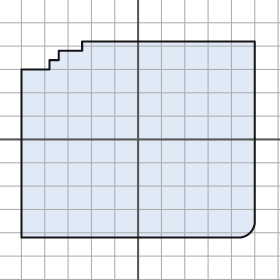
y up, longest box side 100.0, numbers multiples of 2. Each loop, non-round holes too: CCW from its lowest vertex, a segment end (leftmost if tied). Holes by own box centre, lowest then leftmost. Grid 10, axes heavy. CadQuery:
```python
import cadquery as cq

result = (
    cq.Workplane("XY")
    .moveTo(-50.0, -42.0)
    .lineTo(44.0, -42.0)
    .threePointArc((48.0, -40.0), (50.0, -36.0))
    .lineTo(50.0, 42.0)
    .lineTo(-24.0, 42.0)
    .lineTo(-24.0, 38.0)
    .lineTo(-34.0, 38.0)
    .lineTo(-34.0, 34.0)
    .lineTo(-38.0, 34.0)
    .lineTo(-38.0, 30.0)
    .lineTo(-50.0, 30.0)
    .close()
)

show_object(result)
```